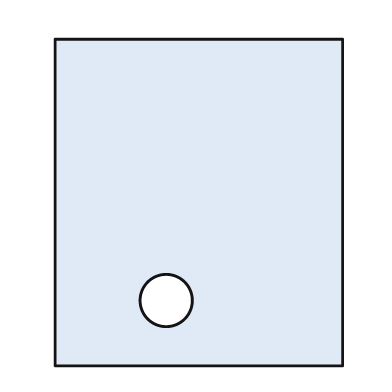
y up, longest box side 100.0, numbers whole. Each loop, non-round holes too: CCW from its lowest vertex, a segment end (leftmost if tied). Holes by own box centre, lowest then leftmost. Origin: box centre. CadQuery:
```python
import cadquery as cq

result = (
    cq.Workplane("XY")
    .moveTo(-44.0, -50.0)
    .lineTo(44.0, -50.0)
    .lineTo(44.0, 50.0)
    .lineTo(-44.0, 50.0)
    .close()
    .moveTo(-10.0, -30.0)
    .circle(8.0)
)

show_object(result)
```